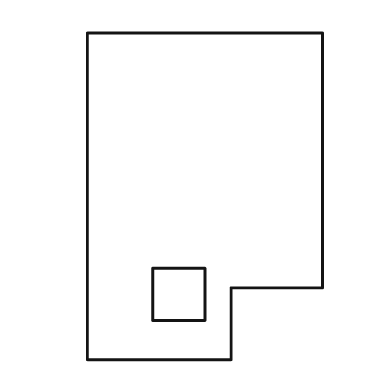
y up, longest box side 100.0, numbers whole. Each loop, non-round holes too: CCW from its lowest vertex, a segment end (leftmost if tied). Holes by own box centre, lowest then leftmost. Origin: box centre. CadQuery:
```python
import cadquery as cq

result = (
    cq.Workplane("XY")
    .moveTo(-36.0, -50.0)
    .lineTo(8.0, -50.0)
    .lineTo(8.0, -28.0)
    .lineTo(36.0, -28.0)
    .lineTo(36.0, 50.0)
    .lineTo(-36.0, 50.0)
    .close()
    .moveTo(-16.0, -38.0)
    .lineTo(0.0, -38.0)
    .lineTo(0.0, -22.0)
    .lineTo(-16.0, -22.0)
    .close()
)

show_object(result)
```